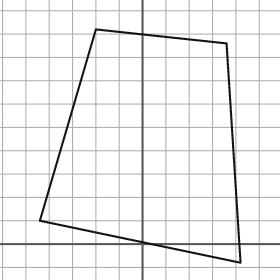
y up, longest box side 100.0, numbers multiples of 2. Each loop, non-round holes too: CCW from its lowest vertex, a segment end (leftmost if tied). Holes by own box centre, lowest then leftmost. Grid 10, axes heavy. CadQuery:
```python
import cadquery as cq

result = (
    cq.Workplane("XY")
    .moveTo(42.0, -8.0)
    .lineTo(36.0, 86.0)
    .lineTo(-20.0, 92.0)
    .lineTo(-44.0, 10.0)
    .close()
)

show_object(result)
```